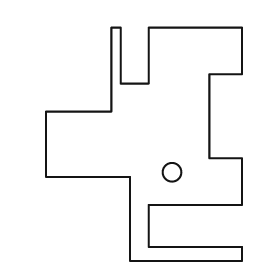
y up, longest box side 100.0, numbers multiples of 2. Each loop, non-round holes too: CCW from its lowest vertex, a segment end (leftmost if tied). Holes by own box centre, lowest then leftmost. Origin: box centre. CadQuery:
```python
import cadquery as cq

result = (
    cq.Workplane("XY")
    .moveTo(-6.0, -50.0)
    .lineTo(42.0, -50.0)
    .lineTo(42.0, -44.0)
    .lineTo(2.0, -44.0)
    .lineTo(2.0, -26.0)
    .lineTo(42.0, -26.0)
    .lineTo(42.0, -6.0)
    .lineTo(28.0, -6.0)
    .lineTo(28.0, 30.0)
    .lineTo(42.0, 30.0)
    .lineTo(42.0, 50.0)
    .lineTo(2.0, 50.0)
    .lineTo(2.0, 26.0)
    .lineTo(-10.0, 26.0)
    .lineTo(-10.0, 50.0)
    .lineTo(-14.0, 50.0)
    .lineTo(-14.0, 14.0)
    .lineTo(-42.0, 14.0)
    .lineTo(-42.0, -14.0)
    .lineTo(-6.0, -14.0)
    .close()
    .moveTo(12.0, -12.0)
    .circle(4.0)
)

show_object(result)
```